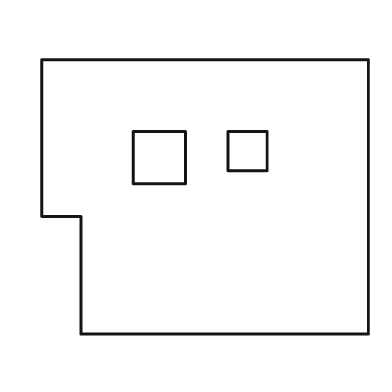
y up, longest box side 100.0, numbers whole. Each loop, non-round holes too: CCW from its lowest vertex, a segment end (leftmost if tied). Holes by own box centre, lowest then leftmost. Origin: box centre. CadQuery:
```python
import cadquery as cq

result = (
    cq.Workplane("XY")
    .moveTo(-38.0, -42.0)
    .lineTo(50.0, -42.0)
    .lineTo(50.0, 42.0)
    .lineTo(-50.0, 42.0)
    .lineTo(-50.0, -6.0)
    .lineTo(-38.0, -6.0)
    .close()
    .moveTo(-22.0, 4.0)
    .lineTo(-6.0, 4.0)
    .lineTo(-6.0, 20.0)
    .lineTo(-22.0, 20.0)
    .close()
    .moveTo(7.0, 8.0)
    .lineTo(19.0, 8.0)
    .lineTo(19.0, 20.0)
    .lineTo(7.0, 20.0)
    .close()
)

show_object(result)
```